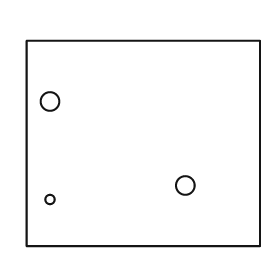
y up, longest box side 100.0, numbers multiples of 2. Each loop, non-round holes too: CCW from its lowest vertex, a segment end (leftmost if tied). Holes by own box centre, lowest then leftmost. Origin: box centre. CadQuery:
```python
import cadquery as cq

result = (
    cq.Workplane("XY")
    .moveTo(-50.0, -44.0)
    .lineTo(50.0, -44.0)
    .lineTo(50.0, 44.0)
    .lineTo(-50.0, 44.0)
    .close()
    .moveTo(-40.0, -24.0)
    .circle(2.0)
    .moveTo(18.0, -18.0)
    .circle(4.0)
    .moveTo(-40.0, 18.0)
    .circle(4.0)
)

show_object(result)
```